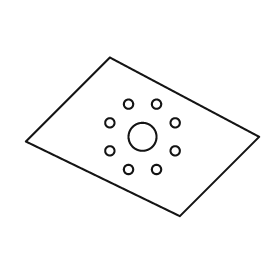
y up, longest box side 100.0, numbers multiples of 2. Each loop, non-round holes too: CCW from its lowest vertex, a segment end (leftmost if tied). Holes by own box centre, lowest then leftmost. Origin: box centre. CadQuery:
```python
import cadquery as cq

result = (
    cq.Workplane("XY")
    .moveTo(16.0, -34.0)
    .lineTo(50.0, 0.0)
    .lineTo(-14.0, 34.0)
    .lineTo(-50.0, -2.0)
    .close()
    .moveTo(-6.0, -14.0)
    .circle(2.0)
    .moveTo(6.0, -14.0)
    .circle(2.0)
    .moveTo(-14.0, -6.0)
    .circle(2.0)
    .moveTo(14.0, -6.0)
    .circle(2.0)
    .moveTo(0.0, 0.0)
    .circle(6.0)
    .moveTo(-14.0, 6.0)
    .circle(2.0)
    .moveTo(14.0, 6.0)
    .circle(2.0)
    .moveTo(-6.0, 14.0)
    .circle(2.0)
    .moveTo(6.0, 14.0)
    .circle(2.0)
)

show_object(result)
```